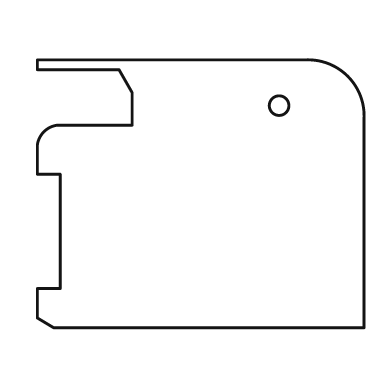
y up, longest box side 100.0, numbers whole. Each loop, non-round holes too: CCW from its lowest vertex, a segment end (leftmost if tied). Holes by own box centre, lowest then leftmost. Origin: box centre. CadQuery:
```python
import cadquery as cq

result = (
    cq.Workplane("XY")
    .moveTo(-45.0, -41.0)
    .lineTo(50.0, -41.0)
    .lineTo(50.0, 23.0)
    .threePointArc((45.0, 36.0), (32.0, 41.0))
    .lineTo(-50.0, 41.0)
    .lineTo(-50.0, 38.0)
    .lineTo(-25.0, 38.0)
    .lineTo(-21.0, 31.0)
    .lineTo(-21.0, 21.0)
    .lineTo(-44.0, 21.0)
    .threePointArc((-48.0, 19.0), (-50.0, 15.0))
    .lineTo(-50.0, 6.0)
    .lineTo(-43.0, 6.0)
    .lineTo(-43.0, -29.0)
    .lineTo(-50.0, -29.0)
    .lineTo(-50.0, -38.0)
    .close()
    .moveTo(24.0, 27.0)
    .circle(3.0)
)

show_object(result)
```